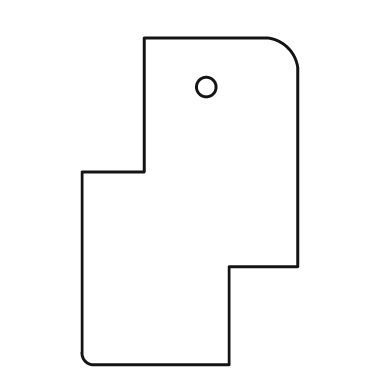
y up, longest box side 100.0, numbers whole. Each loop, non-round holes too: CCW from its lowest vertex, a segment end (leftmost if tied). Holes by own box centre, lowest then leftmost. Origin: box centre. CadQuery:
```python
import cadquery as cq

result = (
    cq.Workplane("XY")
    .moveTo(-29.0, -50.0)
    .lineTo(12.0, -50.0)
    .lineTo(12.0, -20.0)
    .lineTo(33.0, -20.0)
    .lineTo(33.0, 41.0)
    .threePointArc((30.0, 47.0), (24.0, 50.0))
    .lineTo(-14.0, 50.0)
    .lineTo(-14.0, 9.0)
    .lineTo(-33.0, 9.0)
    .lineTo(-33.0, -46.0)
    .threePointArc((-32.0, -49.0), (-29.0, -50.0))
    .close()
    .moveTo(5.0, 35.0)
    .circle(3.0)
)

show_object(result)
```